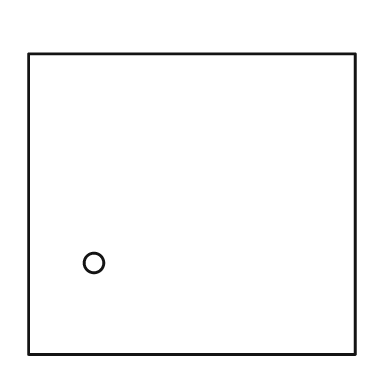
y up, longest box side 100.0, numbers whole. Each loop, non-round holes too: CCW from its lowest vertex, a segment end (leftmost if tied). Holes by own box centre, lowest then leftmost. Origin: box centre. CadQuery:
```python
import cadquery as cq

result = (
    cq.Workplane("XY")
    .moveTo(-50.0, -46.0)
    .lineTo(50.0, -46.0)
    .lineTo(50.0, 46.0)
    .lineTo(-50.0, 46.0)
    .close()
    .moveTo(-30.0, -18.0)
    .circle(3.0)
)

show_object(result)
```